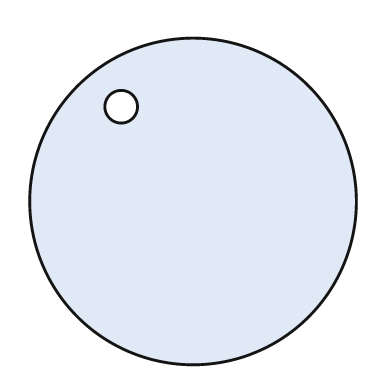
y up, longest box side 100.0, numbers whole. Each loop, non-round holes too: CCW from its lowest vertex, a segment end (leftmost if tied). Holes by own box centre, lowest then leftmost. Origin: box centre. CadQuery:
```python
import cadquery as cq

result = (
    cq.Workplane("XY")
    .moveTo(0.0, 0.0)
    .circle(50.0)
    .moveTo(-22.0, 29.0)
    .circle(5.0)
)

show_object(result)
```